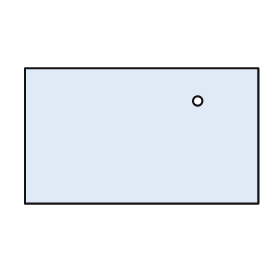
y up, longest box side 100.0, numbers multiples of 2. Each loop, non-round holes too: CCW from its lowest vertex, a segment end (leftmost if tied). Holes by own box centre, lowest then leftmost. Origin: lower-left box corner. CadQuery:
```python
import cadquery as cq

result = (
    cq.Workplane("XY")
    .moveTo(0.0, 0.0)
    .lineTo(100.0, 0.0)
    .lineTo(100.0, 58.0)
    .lineTo(0.0, 58.0)
    .close()
    .moveTo(74.0, 44.0)
    .circle(2.0)
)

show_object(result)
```